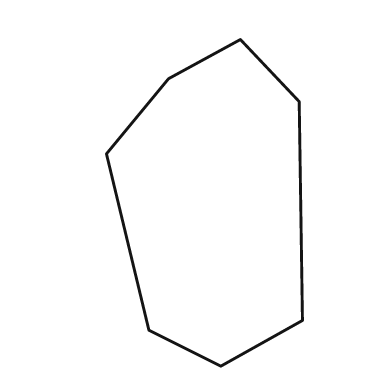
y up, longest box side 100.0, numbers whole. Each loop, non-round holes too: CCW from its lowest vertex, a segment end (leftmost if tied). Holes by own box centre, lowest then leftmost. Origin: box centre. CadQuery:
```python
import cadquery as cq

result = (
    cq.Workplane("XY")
    .moveTo(5.0, -50.0)
    .lineTo(30.0, -36.0)
    .lineTo(29.0, 31.0)
    .lineTo(11.0, 50.0)
    .lineTo(-11.0, 38.0)
    .lineTo(-30.0, 15.0)
    .lineTo(-17.0, -39.0)
    .close()
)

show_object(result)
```